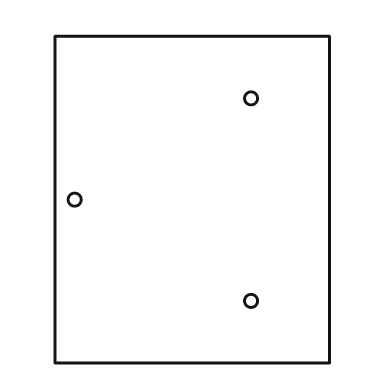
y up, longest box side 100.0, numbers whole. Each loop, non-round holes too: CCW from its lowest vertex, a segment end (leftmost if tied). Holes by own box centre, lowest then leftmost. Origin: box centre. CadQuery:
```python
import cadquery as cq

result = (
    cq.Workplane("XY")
    .moveTo(-42.0, -50.0)
    .lineTo(42.0, -50.0)
    .lineTo(42.0, 50.0)
    .lineTo(-42.0, 50.0)
    .close()
    .moveTo(18.0, -31.0)
    .circle(2.0)
    .moveTo(-36.0, 0.0)
    .circle(2.0)
    .moveTo(18.0, 31.0)
    .circle(2.0)
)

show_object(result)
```